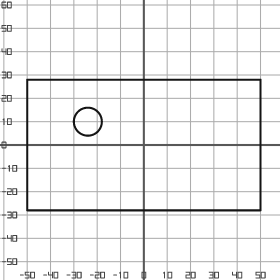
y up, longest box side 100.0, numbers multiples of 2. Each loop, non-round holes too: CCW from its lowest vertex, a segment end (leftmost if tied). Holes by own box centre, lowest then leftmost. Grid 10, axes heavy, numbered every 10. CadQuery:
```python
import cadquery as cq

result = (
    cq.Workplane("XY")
    .moveTo(-50.0, -28.0)
    .lineTo(50.0, -28.0)
    .lineTo(50.0, 28.0)
    .lineTo(-50.0, 28.0)
    .close()
    .moveTo(-24.0, 10.0)
    .circle(6.0)
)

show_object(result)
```